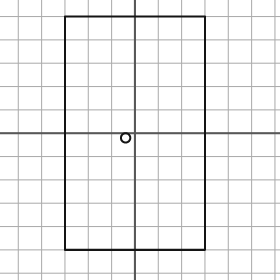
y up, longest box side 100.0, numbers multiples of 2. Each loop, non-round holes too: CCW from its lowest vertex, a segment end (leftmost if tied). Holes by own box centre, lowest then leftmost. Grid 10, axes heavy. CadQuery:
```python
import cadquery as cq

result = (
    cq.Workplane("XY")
    .moveTo(-30.0, -50.0)
    .lineTo(30.0, -50.0)
    .lineTo(30.0, 50.0)
    .lineTo(-30.0, 50.0)
    .close()
    .moveTo(-4.0, -2.0)
    .circle(2.0)
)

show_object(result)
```